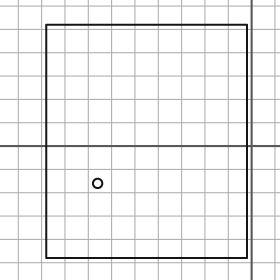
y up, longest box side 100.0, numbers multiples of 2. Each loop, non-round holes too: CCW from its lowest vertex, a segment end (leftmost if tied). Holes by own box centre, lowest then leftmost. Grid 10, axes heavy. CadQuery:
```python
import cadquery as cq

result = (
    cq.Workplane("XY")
    .moveTo(-88.0, -48.0)
    .lineTo(-2.0, -48.0)
    .lineTo(-2.0, 52.0)
    .lineTo(-88.0, 52.0)
    .close()
    .moveTo(-66.0, -16.0)
    .circle(2.0)
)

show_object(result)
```